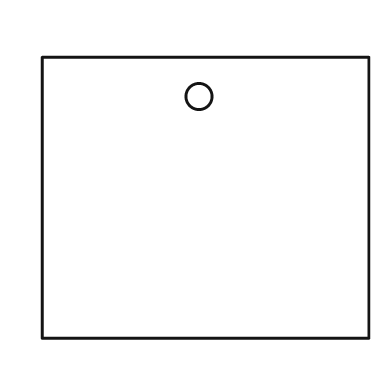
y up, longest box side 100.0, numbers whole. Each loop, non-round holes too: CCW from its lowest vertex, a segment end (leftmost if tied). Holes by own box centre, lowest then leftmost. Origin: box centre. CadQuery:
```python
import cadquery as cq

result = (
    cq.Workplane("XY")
    .moveTo(-50.0, -43.0)
    .lineTo(50.0, -43.0)
    .lineTo(50.0, 43.0)
    .lineTo(-50.0, 43.0)
    .close()
    .moveTo(-2.0, 31.0)
    .circle(4.0)
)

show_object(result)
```